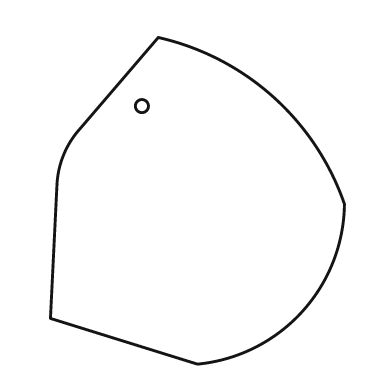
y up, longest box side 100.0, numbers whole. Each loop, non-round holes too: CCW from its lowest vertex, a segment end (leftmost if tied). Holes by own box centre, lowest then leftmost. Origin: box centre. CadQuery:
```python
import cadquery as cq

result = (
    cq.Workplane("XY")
    .moveTo(0.0, -50.0)
    .threePointArc((32.0, -34.0), (45.0, -1.0))
    .threePointArc((23.0, 32.0), (-12.0, 50.0))
    .lineTo(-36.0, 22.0)
    .threePointArc((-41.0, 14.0), (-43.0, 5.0))
    .lineTo(-45.0, -36.0)
    .close()
    .moveTo(-17.0, 29.0)
    .circle(2.0)
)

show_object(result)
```